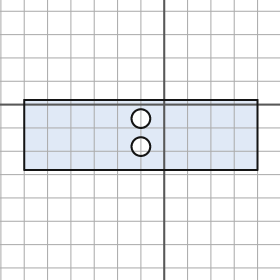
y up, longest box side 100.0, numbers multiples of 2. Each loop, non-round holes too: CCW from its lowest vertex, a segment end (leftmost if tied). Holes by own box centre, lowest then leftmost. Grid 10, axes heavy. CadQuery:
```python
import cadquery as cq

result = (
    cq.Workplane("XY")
    .moveTo(-60.0, -28.0)
    .lineTo(40.0, -28.0)
    .lineTo(40.0, 2.0)
    .lineTo(-60.0, 2.0)
    .close()
    .moveTo(-10.0, -18.0)
    .circle(4.0)
    .moveTo(-10.0, -6.0)
    .circle(4.0)
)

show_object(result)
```